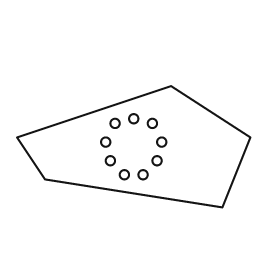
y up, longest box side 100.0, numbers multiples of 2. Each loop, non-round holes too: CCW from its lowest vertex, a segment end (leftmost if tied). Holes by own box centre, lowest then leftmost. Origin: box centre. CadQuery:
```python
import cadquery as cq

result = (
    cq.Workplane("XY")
    .moveTo(38.0, -26.0)
    .lineTo(50.0, 4.0)
    .lineTo(16.0, 26.0)
    .lineTo(-50.0, 4.0)
    .lineTo(-38.0, -14.0)
    .close()
    .moveTo(-4.0, -12.0)
    .circle(2.0)
    .moveTo(4.0, -12.0)
    .circle(2.0)
    .moveTo(-10.0, -6.0)
    .circle(2.0)
    .moveTo(10.0, -6.0)
    .circle(2.0)
    .moveTo(-12.0, 2.0)
    .circle(2.0)
    .moveTo(12.0, 2.0)
    .circle(2.0)
    .moveTo(-8.0, 10.0)
    .circle(2.0)
    .moveTo(8.0, 10.0)
    .circle(2.0)
    .moveTo(0.0, 12.0)
    .circle(2.0)
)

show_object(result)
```